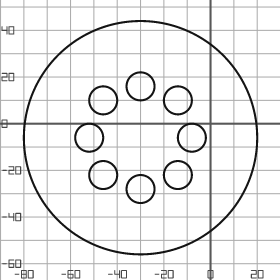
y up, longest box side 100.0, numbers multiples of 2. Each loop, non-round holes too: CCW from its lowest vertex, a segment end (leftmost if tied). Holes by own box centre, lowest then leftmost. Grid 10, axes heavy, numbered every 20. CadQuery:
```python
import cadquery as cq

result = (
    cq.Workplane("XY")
    .moveTo(-30.0, -6.0)
    .circle(50.0)
    .moveTo(-30.0, -28.0)
    .circle(6.0)
    .moveTo(-46.0, -22.0)
    .circle(6.0)
    .moveTo(-14.0, -22.0)
    .circle(6.0)
    .moveTo(-52.0, -6.0)
    .circle(6.0)
    .moveTo(-8.0, -6.0)
    .circle(6.0)
    .moveTo(-46.0, 10.0)
    .circle(6.0)
    .moveTo(-14.0, 10.0)
    .circle(6.0)
    .moveTo(-30.0, 16.0)
    .circle(6.0)
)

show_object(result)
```